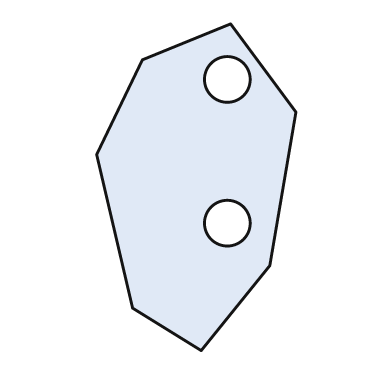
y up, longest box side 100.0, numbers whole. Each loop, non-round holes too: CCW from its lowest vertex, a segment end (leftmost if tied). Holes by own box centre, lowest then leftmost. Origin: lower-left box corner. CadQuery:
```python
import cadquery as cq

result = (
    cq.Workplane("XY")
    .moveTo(32.0, 0.0)
    .lineTo(53.0, 26.0)
    .lineTo(61.0, 73.0)
    .lineTo(41.0, 100.0)
    .lineTo(14.0, 89.0)
    .lineTo(0.0, 60.0)
    .lineTo(11.0, 13.0)
    .close()
    .moveTo(40.0, 39.0)
    .circle(7.0)
    .moveTo(40.0, 83.0)
    .circle(7.0)
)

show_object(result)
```